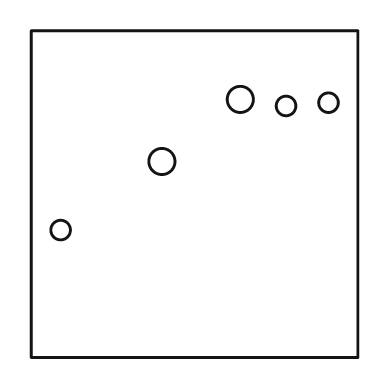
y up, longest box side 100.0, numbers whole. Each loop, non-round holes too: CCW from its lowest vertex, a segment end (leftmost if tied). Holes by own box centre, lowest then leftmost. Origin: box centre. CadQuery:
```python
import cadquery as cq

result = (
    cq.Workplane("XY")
    .moveTo(-50.0, -50.0)
    .lineTo(50.0, -50.0)
    .lineTo(50.0, 50.0)
    .lineTo(-50.0, 50.0)
    .close()
    .moveTo(-41.0, -11.0)
    .circle(3.0)
    .moveTo(-10.0, 10.0)
    .circle(4.0)
    .moveTo(28.0, 27.0)
    .circle(3.0)
    .moveTo(41.0, 28.0)
    .circle(3.0)
    .moveTo(14.0, 29.0)
    .circle(4.0)
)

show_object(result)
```